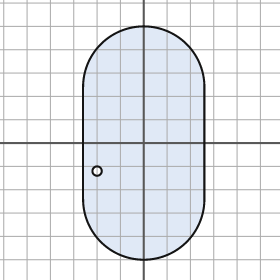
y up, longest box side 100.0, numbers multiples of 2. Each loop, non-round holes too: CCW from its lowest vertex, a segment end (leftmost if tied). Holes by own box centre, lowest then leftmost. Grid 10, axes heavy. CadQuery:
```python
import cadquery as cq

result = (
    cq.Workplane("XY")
    .moveTo(-26.0, -24.0)
    .threePointArc((0.0, -50.0), (26.0, -24.0))
    .lineTo(26.0, 24.0)
    .threePointArc((0.0, 50.0), (-26.0, 24.0))
    .close()
    .moveTo(-20.0, -12.0)
    .circle(2.0)
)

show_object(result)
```